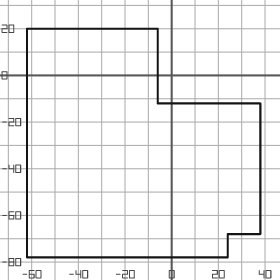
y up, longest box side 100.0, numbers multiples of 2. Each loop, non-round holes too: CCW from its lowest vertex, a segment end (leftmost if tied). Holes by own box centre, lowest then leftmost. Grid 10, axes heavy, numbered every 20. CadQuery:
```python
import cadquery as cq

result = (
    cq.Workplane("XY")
    .moveTo(-62.0, -78.0)
    .lineTo(24.0, -78.0)
    .lineTo(24.0, -68.0)
    .lineTo(38.0, -68.0)
    .lineTo(38.0, -12.0)
    .lineTo(-6.0, -12.0)
    .lineTo(-6.0, 20.0)
    .lineTo(-62.0, 20.0)
    .close()
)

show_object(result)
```